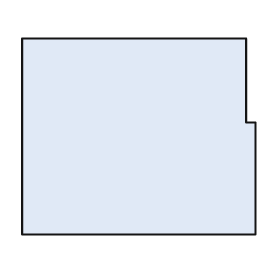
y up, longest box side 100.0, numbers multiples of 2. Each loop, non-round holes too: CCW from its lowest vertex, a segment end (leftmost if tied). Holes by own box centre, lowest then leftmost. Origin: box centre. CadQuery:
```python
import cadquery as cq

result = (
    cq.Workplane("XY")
    .moveTo(-50.0, -42.0)
    .lineTo(50.0, -42.0)
    .lineTo(50.0, 6.0)
    .lineTo(46.0, 6.0)
    .lineTo(46.0, 42.0)
    .lineTo(-50.0, 42.0)
    .close()
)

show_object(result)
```